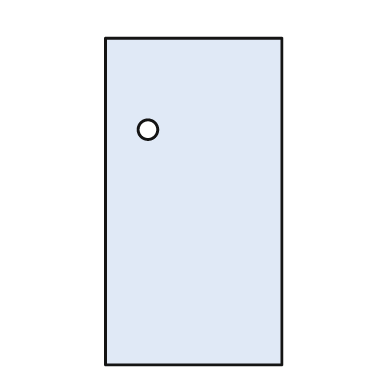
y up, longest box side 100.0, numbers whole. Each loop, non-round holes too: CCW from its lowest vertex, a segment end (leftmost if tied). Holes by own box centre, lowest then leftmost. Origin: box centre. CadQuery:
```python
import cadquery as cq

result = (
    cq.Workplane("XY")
    .moveTo(-27.0, -50.0)
    .lineTo(27.0, -50.0)
    .lineTo(27.0, 50.0)
    .lineTo(-27.0, 50.0)
    .close()
    .moveTo(-14.0, 22.0)
    .circle(3.0)
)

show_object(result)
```